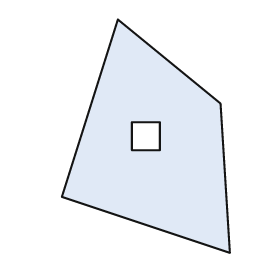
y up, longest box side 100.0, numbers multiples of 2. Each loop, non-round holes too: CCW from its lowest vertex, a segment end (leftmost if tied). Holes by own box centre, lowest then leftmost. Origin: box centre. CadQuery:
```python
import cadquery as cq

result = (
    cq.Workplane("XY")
    .moveTo(36.0, -50.0)
    .lineTo(32.0, 14.0)
    .lineTo(-12.0, 50.0)
    .lineTo(-36.0, -26.0)
    .close()
    .moveTo(-6.0, -6.0)
    .lineTo(6.0, -6.0)
    .lineTo(6.0, 6.0)
    .lineTo(-6.0, 6.0)
    .close()
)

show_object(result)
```